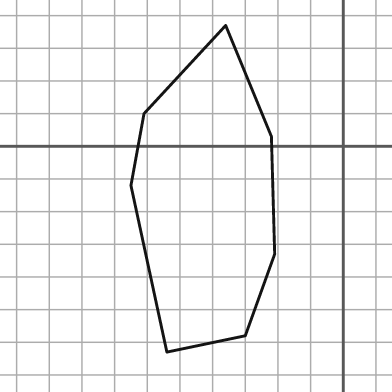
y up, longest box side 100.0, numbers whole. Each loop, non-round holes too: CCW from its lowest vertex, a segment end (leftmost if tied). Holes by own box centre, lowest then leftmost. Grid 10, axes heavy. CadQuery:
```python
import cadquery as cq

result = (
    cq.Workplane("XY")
    .moveTo(-54.0, -63.0)
    .lineTo(-30.0, -58.0)
    .lineTo(-21.0, -33.0)
    .lineTo(-22.0, 3.0)
    .lineTo(-36.0, 37.0)
    .lineTo(-61.0, 10.0)
    .lineTo(-65.0, -12.0)
    .close()
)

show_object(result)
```